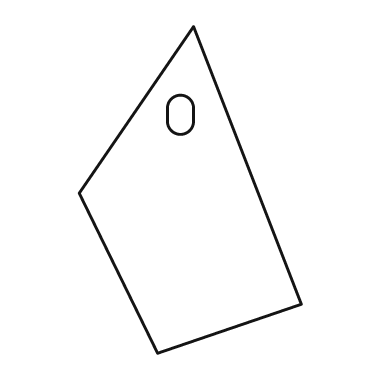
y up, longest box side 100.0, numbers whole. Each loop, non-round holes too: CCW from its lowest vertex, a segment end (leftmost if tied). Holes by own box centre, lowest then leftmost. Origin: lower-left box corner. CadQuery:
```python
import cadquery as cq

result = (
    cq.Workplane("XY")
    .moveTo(24.0, 0.0)
    .lineTo(68.0, 15.0)
    .lineTo(35.0, 100.0)
    .lineTo(0.0, 49.0)
    .close()
    .moveTo(27.0, 71.0)
    .threePointArc((31.0, 67.0), (35.0, 71.0))
    .lineTo(35.0, 75.0)
    .threePointArc((31.0, 79.0), (27.0, 75.0))
    .close()
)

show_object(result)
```